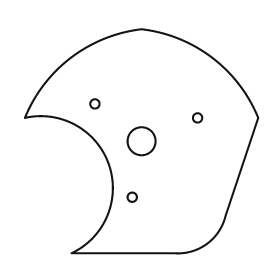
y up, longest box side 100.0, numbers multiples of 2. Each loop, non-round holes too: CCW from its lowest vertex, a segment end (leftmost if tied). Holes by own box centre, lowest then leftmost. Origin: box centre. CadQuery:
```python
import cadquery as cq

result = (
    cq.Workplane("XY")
    .moveTo(-30.0, -48.0)
    .lineTo(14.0, -48.0)
    .threePointArc((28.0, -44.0), (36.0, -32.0))
    .lineTo(50.0, 10.0)
    .threePointArc((30.0, 36.0), (0.0, 48.0))
    .threePointArc((-30.0, 36.0), (-50.0, 10.0))
    .threePointArc((-14.0, -10.0), (-30.0, -48.0))
    .close()
    .moveTo(-4.0, -24.0)
    .circle(2.0)
    .moveTo(0.0, 0.0)
    .circle(6.0)
    .moveTo(24.0, 10.0)
    .circle(2.0)
    .moveTo(-20.0, 16.0)
    .circle(2.0)
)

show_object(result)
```